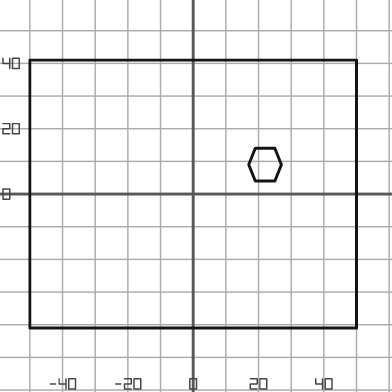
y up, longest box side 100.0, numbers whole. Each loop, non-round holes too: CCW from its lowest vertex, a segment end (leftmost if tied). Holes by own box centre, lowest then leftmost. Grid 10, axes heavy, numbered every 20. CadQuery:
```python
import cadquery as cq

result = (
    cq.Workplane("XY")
    .moveTo(-50.0, -41.0)
    .lineTo(50.0, -41.0)
    .lineTo(50.0, 41.0)
    .lineTo(-50.0, 41.0)
    .close()
    .moveTo(19.0, 4.0)
    .lineTo(25.0, 4.0)
    .lineTo(27.0, 9.0)
    .lineTo(25.0, 14.0)
    .lineTo(19.0, 14.0)
    .lineTo(17.0, 9.0)
    .close()
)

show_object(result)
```